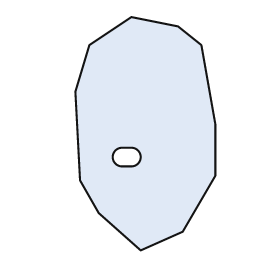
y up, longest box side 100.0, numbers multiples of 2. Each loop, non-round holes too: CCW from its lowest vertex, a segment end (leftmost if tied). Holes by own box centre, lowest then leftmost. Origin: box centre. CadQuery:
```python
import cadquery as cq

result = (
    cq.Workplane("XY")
    .moveTo(-2.0, -50.0)
    .lineTo(16.0, -42.0)
    .lineTo(30.0, -18.0)
    .lineTo(30.0, 4.0)
    .lineTo(24.0, 38.0)
    .lineTo(14.0, 46.0)
    .lineTo(-6.0, 50.0)
    .lineTo(-24.0, 38.0)
    .lineTo(-30.0, 18.0)
    .lineTo(-28.0, -20.0)
    .lineTo(-20.0, -34.0)
    .close()
    .moveTo(-10.0, -14.0)
    .lineTo(-6.0, -14.0)
    .threePointArc((-2.0, -10.0), (-6.0, -6.0))
    .lineTo(-10.0, -6.0)
    .threePointArc((-14.0, -10.0), (-10.0, -14.0))
    .close()
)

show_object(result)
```